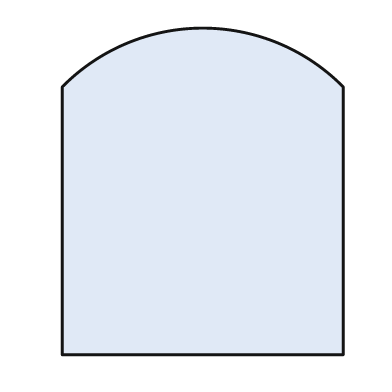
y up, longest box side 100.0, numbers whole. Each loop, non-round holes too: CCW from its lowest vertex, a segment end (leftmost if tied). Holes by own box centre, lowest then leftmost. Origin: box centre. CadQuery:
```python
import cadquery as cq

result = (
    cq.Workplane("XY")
    .moveTo(-43.0, -50.0)
    .lineTo(43.0, -50.0)
    .lineTo(43.0, 32.0)
    .threePointArc((0.0, 50.0), (-43.0, 32.0))
    .close()
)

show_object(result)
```